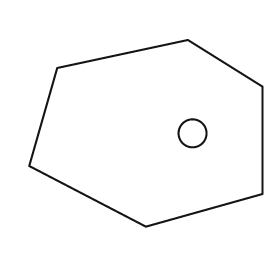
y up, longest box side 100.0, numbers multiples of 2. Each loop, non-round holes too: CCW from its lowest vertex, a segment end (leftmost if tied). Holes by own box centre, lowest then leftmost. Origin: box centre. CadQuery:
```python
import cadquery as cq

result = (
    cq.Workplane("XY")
    .moveTo(0.0, -40.0)
    .lineTo(50.0, -26.0)
    .lineTo(50.0, 20.0)
    .lineTo(18.0, 40.0)
    .lineTo(-38.0, 28.0)
    .lineTo(-50.0, -14.0)
    .close()
    .moveTo(20.0, 0.0)
    .circle(6.0)
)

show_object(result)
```